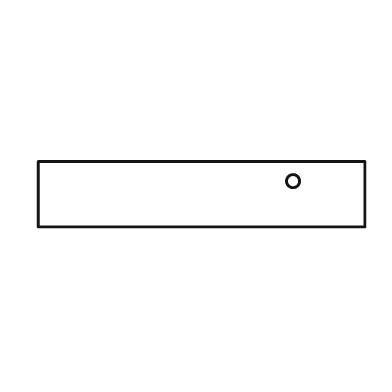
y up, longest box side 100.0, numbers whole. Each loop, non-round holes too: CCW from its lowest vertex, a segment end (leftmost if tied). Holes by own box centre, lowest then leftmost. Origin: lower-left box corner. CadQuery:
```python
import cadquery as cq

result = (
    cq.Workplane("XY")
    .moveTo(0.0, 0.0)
    .lineTo(100.0, 0.0)
    .lineTo(100.0, 20.0)
    .lineTo(0.0, 20.0)
    .close()
    .moveTo(78.0, 14.0)
    .circle(2.0)
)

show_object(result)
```